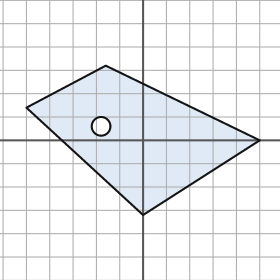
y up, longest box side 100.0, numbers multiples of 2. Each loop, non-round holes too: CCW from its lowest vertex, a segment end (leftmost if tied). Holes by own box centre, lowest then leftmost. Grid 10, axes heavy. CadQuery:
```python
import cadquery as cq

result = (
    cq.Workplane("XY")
    .moveTo(0.0, -32.0)
    .lineTo(50.0, 0.0)
    .lineTo(-16.0, 32.0)
    .lineTo(-50.0, 14.0)
    .close()
    .moveTo(-18.0, 6.0)
    .circle(4.0)
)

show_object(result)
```